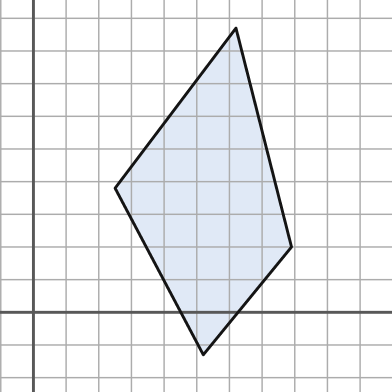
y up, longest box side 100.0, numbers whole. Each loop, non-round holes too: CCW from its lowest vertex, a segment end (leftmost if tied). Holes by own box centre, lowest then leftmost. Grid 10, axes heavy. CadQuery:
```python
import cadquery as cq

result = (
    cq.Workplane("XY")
    .moveTo(52.0, -13.0)
    .lineTo(79.0, 20.0)
    .lineTo(62.0, 87.0)
    .lineTo(25.0, 38.0)
    .close()
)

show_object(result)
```